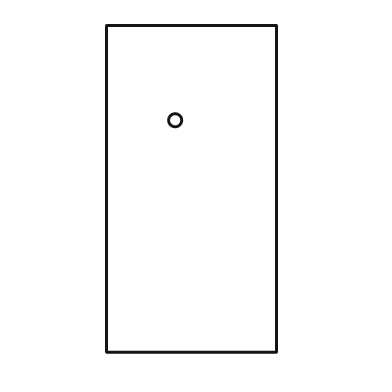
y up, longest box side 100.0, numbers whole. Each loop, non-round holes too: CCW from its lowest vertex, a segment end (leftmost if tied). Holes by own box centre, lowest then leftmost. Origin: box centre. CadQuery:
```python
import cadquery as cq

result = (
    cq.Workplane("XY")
    .moveTo(-26.0, -50.0)
    .lineTo(26.0, -50.0)
    .lineTo(26.0, 50.0)
    .lineTo(-26.0, 50.0)
    .close()
    .moveTo(-5.0, 21.0)
    .circle(2.0)
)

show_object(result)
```